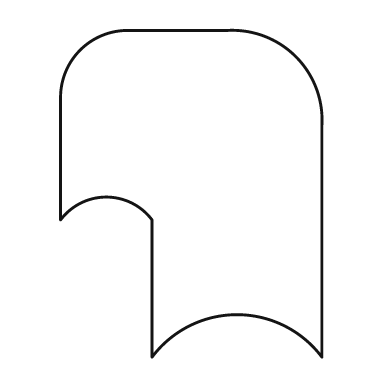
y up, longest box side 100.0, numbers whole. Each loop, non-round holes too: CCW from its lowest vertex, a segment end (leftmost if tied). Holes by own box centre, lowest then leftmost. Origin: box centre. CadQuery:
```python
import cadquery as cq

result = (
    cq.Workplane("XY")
    .moveTo(-12.0, -50.0)
    .threePointArc((14.0, -37.0), (40.0, -50.0))
    .lineTo(40.0, 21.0)
    .threePointArc((32.0, 42.0), (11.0, 50.0))
    .lineTo(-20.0, 50.0)
    .threePointArc((-34.0, 44.0), (-40.0, 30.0))
    .lineTo(-40.0, -8.0)
    .threePointArc((-26.0, -1.0), (-12.0, -8.0))
    .close()
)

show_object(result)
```